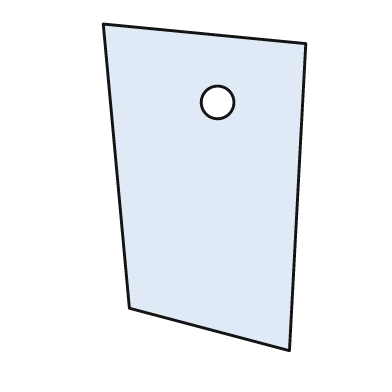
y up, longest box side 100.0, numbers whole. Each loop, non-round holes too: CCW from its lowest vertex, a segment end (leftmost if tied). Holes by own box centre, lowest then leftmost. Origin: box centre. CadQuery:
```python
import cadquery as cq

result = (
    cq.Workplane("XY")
    .moveTo(26.0, -50.0)
    .lineTo(31.0, 44.0)
    .lineTo(-31.0, 50.0)
    .lineTo(-23.0, -37.0)
    .close()
    .moveTo(4.0, 26.0)
    .circle(5.0)
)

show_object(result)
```